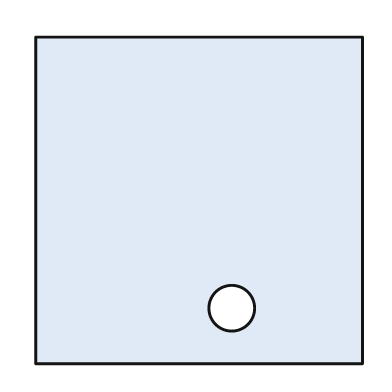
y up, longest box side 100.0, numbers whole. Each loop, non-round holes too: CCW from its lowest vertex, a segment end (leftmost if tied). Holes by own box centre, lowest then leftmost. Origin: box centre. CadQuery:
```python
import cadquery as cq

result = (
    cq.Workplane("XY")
    .moveTo(-50.0, -50.0)
    .lineTo(50.0, -50.0)
    .lineTo(50.0, 50.0)
    .lineTo(-50.0, 50.0)
    .close()
    .moveTo(10.0, -33.0)
    .circle(7.0)
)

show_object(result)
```